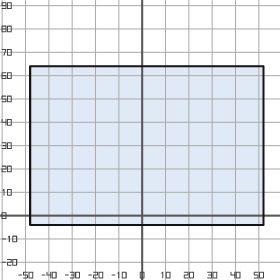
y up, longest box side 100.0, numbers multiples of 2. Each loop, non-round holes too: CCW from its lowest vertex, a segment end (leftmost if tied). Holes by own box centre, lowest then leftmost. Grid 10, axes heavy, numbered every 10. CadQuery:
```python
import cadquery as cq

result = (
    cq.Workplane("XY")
    .moveTo(-48.0, -4.0)
    .lineTo(52.0, -4.0)
    .lineTo(52.0, 64.0)
    .lineTo(-48.0, 64.0)
    .close()
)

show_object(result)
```